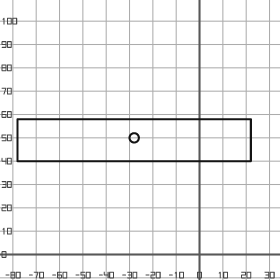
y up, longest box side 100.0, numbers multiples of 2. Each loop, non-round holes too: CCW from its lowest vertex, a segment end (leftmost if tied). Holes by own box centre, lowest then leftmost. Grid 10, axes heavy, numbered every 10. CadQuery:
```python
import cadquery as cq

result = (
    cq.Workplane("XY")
    .moveTo(-78.0, 40.0)
    .lineTo(22.0, 40.0)
    .lineTo(22.0, 58.0)
    .lineTo(-78.0, 58.0)
    .close()
    .moveTo(-28.0, 50.0)
    .circle(2.0)
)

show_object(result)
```